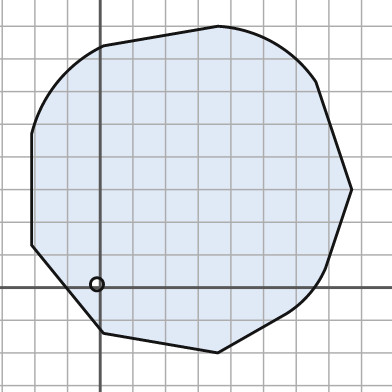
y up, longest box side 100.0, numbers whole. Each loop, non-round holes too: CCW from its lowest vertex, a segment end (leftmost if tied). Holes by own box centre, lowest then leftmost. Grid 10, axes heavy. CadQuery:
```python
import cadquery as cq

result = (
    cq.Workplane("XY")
    .moveTo(36.0, -20.0)
    .lineTo(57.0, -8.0)
    .threePointArc((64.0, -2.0), (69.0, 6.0))
    .lineTo(77.0, 30.0)
    .lineTo(66.0, 63.0)
    .threePointArc((53.0, 75.0), (36.0, 80.0))
    .lineTo(1.0, 74.0)
    .threePointArc((-13.0, 63.0), (-21.0, 47.0))
    .lineTo(-21.0, 13.0)
    .lineTo(1.0, -14.0)
    .close()
    .moveTo(-1.0, 1.0)
    .circle(2.0)
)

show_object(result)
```